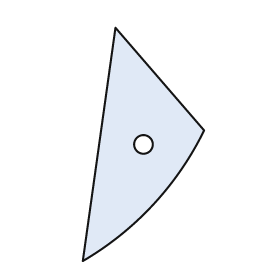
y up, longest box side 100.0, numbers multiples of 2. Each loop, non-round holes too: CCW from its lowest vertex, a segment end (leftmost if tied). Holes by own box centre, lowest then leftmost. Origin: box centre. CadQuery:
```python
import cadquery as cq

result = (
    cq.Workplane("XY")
    .moveTo(-26.0, -50.0)
    .threePointArc((4.0, -26.0), (26.0, 6.0))
    .lineTo(-12.0, 50.0)
    .close()
    .moveTo(0.0, 0.0)
    .circle(4.0)
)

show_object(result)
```